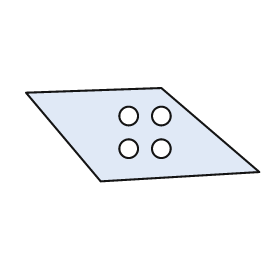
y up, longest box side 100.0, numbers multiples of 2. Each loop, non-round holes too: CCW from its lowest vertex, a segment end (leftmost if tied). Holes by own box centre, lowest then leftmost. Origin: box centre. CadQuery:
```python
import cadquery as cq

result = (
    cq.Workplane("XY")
    .moveTo(-18.0, -20.0)
    .lineTo(50.0, -16.0)
    .lineTo(8.0, 20.0)
    .lineTo(-50.0, 18.0)
    .close()
    .moveTo(-6.0, -6.0)
    .circle(4.0)
    .moveTo(8.0, -6.0)
    .circle(4.0)
    .moveTo(-6.0, 8.0)
    .circle(4.0)
    .moveTo(8.0, 8.0)
    .circle(4.0)
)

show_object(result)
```